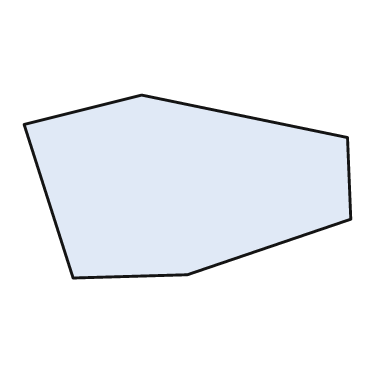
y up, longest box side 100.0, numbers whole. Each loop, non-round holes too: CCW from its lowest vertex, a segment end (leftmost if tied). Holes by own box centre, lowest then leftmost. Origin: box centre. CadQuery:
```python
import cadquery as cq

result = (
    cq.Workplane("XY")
    .moveTo(-35.0, -28.0)
    .lineTo(0.0, -27.0)
    .lineTo(50.0, -10.0)
    .lineTo(49.0, 15.0)
    .lineTo(-14.0, 28.0)
    .lineTo(-50.0, 19.0)
    .close()
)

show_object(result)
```